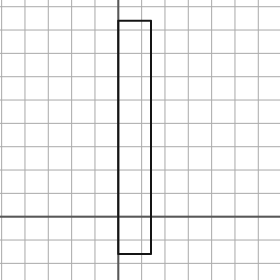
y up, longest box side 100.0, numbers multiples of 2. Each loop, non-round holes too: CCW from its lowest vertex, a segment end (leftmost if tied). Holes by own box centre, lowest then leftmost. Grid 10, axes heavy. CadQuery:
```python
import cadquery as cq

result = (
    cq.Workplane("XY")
    .moveTo(0.0, -16.0)
    .lineTo(14.0, -16.0)
    .lineTo(14.0, 84.0)
    .lineTo(0.0, 84.0)
    .close()
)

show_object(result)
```